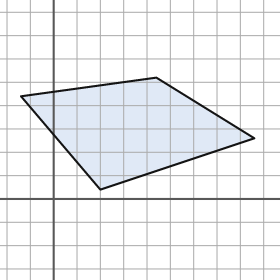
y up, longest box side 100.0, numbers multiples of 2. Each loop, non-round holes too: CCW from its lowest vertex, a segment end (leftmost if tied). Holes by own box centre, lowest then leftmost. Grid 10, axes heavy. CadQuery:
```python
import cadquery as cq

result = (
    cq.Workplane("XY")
    .moveTo(20.0, 4.0)
    .lineTo(86.0, 26.0)
    .lineTo(44.0, 52.0)
    .lineTo(-14.0, 44.0)
    .close()
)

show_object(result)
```